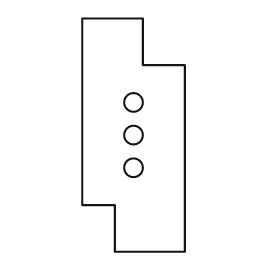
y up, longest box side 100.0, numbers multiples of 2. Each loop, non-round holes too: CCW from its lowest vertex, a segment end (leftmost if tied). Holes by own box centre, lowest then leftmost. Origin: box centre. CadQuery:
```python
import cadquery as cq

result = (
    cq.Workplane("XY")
    .moveTo(-8.0, -50.0)
    .lineTo(22.0, -50.0)
    .lineTo(22.0, 30.0)
    .lineTo(4.0, 30.0)
    .lineTo(4.0, 50.0)
    .lineTo(-22.0, 50.0)
    .lineTo(-22.0, -30.0)
    .lineTo(-8.0, -30.0)
    .close()
    .moveTo(0.0, -14.0)
    .circle(4.0)
    .moveTo(0.0, 0.0)
    .circle(4.0)
    .moveTo(0.0, 14.0)
    .circle(4.0)
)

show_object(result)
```